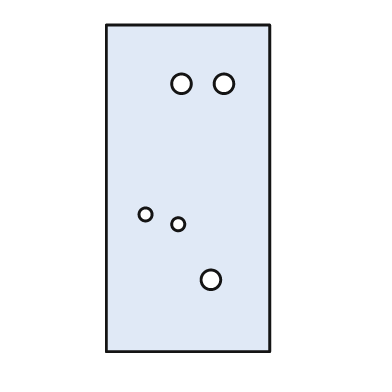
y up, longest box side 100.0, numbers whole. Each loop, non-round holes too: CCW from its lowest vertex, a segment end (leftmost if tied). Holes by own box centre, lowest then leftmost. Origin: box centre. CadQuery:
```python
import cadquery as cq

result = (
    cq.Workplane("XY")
    .moveTo(-25.0, -50.0)
    .lineTo(25.0, -50.0)
    .lineTo(25.0, 50.0)
    .lineTo(-25.0, 50.0)
    .close()
    .moveTo(7.0, -28.0)
    .circle(3.0)
    .moveTo(-3.0, -11.0)
    .circle(2.0)
    .moveTo(-13.0, -8.0)
    .circle(2.0)
    .moveTo(-2.0, 32.0)
    .circle(3.0)
    .moveTo(11.0, 32.0)
    .circle(3.0)
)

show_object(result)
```